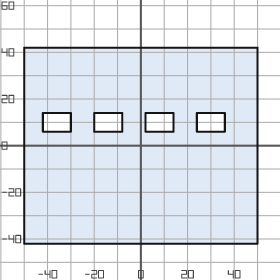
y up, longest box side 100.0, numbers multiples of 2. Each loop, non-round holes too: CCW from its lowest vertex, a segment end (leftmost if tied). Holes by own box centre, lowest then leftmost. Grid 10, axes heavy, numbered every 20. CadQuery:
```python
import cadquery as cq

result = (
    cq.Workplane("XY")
    .moveTo(-50.0, -42.0)
    .lineTo(50.0, -42.0)
    .lineTo(50.0, 42.0)
    .lineTo(-50.0, 42.0)
    .close()
    .moveTo(-42.0, 6.0)
    .lineTo(-30.0, 6.0)
    .lineTo(-30.0, 14.0)
    .lineTo(-42.0, 14.0)
    .close()
    .moveTo(-20.0, 6.0)
    .lineTo(-8.0, 6.0)
    .lineTo(-8.0, 14.0)
    .lineTo(-20.0, 14.0)
    .close()
    .moveTo(2.0, 6.0)
    .lineTo(14.0, 6.0)
    .lineTo(14.0, 14.0)
    .lineTo(2.0, 14.0)
    .close()
    .moveTo(24.0, 6.0)
    .lineTo(36.0, 6.0)
    .lineTo(36.0, 14.0)
    .lineTo(24.0, 14.0)
    .close()
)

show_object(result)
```